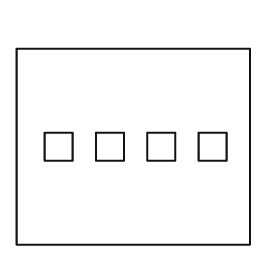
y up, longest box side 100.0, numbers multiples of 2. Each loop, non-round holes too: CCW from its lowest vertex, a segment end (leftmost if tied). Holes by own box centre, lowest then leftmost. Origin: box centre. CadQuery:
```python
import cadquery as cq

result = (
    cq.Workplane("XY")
    .moveTo(-50.0, -42.0)
    .lineTo(50.0, -42.0)
    .lineTo(50.0, 42.0)
    .lineTo(-50.0, 42.0)
    .close()
    .moveTo(-38.0, -6.0)
    .lineTo(-26.0, -6.0)
    .lineTo(-26.0, 6.0)
    .lineTo(-38.0, 6.0)
    .close()
    .moveTo(-16.0, -6.0)
    .lineTo(-4.0, -6.0)
    .lineTo(-4.0, 6.0)
    .lineTo(-16.0, 6.0)
    .close()
    .moveTo(6.0, -6.0)
    .lineTo(18.0, -6.0)
    .lineTo(18.0, 6.0)
    .lineTo(6.0, 6.0)
    .close()
    .moveTo(28.0, -6.0)
    .lineTo(40.0, -6.0)
    .lineTo(40.0, 6.0)
    .lineTo(28.0, 6.0)
    .close()
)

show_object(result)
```